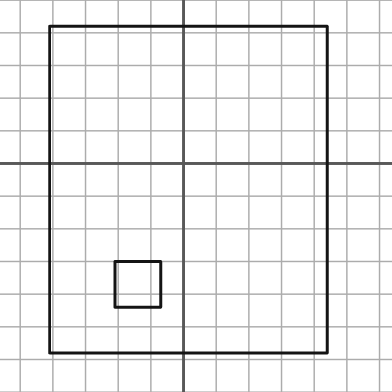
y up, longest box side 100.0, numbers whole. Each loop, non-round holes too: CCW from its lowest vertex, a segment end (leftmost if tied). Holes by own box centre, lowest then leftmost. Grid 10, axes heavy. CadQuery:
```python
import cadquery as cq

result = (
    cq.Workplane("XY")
    .moveTo(-41.0, -58.0)
    .lineTo(44.0, -58.0)
    .lineTo(44.0, 42.0)
    .lineTo(-41.0, 42.0)
    .close()
    .moveTo(-21.0, -44.0)
    .lineTo(-7.0, -44.0)
    .lineTo(-7.0, -30.0)
    .lineTo(-21.0, -30.0)
    .close()
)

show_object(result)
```